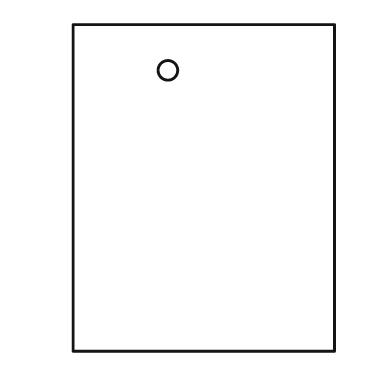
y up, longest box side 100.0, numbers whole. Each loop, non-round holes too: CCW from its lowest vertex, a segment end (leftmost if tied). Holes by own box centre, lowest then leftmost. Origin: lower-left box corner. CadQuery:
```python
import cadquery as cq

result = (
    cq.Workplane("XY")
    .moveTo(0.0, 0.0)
    .lineTo(80.0, 0.0)
    .lineTo(80.0, 100.0)
    .lineTo(0.0, 100.0)
    .close()
    .moveTo(29.0, 86.0)
    .circle(3.0)
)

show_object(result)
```